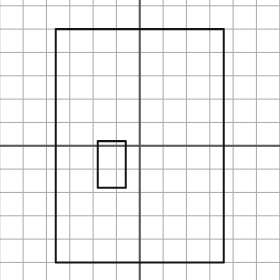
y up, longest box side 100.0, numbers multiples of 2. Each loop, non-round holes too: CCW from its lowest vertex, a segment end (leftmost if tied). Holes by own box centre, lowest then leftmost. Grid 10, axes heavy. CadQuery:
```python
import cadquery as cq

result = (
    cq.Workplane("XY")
    .moveTo(-36.0, -50.0)
    .lineTo(36.0, -50.0)
    .lineTo(36.0, 50.0)
    .lineTo(-36.0, 50.0)
    .close()
    .moveTo(-18.0, -18.0)
    .lineTo(-6.0, -18.0)
    .lineTo(-6.0, 2.0)
    .lineTo(-18.0, 2.0)
    .close()
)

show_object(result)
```